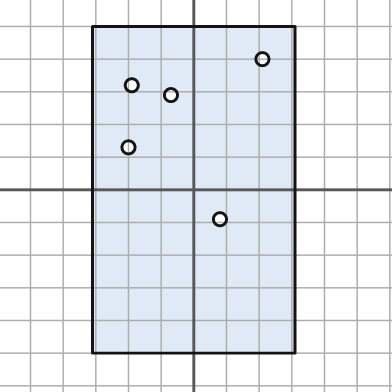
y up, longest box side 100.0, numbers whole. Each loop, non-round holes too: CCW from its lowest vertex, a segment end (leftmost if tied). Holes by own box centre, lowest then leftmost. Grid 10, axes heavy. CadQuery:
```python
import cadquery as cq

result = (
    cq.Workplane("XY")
    .moveTo(-31.0, -50.0)
    .lineTo(31.0, -50.0)
    .lineTo(31.0, 50.0)
    .lineTo(-31.0, 50.0)
    .close()
    .moveTo(8.0, -9.0)
    .circle(2.0)
    .moveTo(-20.0, 13.0)
    .circle(2.0)
    .moveTo(-7.0, 29.0)
    .circle(2.0)
    .moveTo(-19.0, 32.0)
    .circle(2.0)
    .moveTo(21.0, 40.0)
    .circle(2.0)
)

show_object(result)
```